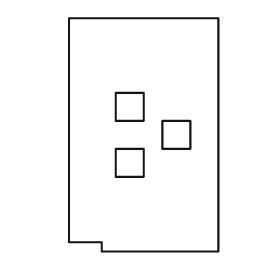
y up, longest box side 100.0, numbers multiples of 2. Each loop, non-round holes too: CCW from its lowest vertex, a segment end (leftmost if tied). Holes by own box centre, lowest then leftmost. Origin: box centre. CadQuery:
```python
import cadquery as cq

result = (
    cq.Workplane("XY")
    .moveTo(-18.0, -50.0)
    .lineTo(32.0, -50.0)
    .lineTo(32.0, 50.0)
    .lineTo(-32.0, 50.0)
    .lineTo(-32.0, -46.0)
    .lineTo(-18.0, -46.0)
    .close()
    .moveTo(-12.0, -18.0)
    .lineTo(0.0, -18.0)
    .lineTo(0.0, -6.0)
    .lineTo(-12.0, -6.0)
    .close()
    .moveTo(8.0, -6.0)
    .lineTo(20.0, -6.0)
    .lineTo(20.0, 6.0)
    .lineTo(8.0, 6.0)
    .close()
    .moveTo(-12.0, 6.0)
    .lineTo(0.0, 6.0)
    .lineTo(0.0, 18.0)
    .lineTo(-12.0, 18.0)
    .close()
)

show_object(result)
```